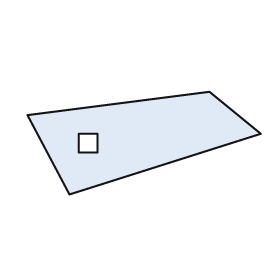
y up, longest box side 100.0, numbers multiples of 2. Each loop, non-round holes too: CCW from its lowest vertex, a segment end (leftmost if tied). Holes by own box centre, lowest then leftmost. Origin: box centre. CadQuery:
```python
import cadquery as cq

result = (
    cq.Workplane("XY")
    .moveTo(-32.0, -22.0)
    .lineTo(50.0, 4.0)
    .lineTo(28.0, 22.0)
    .lineTo(-50.0, 12.0)
    .close()
    .moveTo(-28.0, -4.0)
    .lineTo(-20.0, -4.0)
    .lineTo(-20.0, 4.0)
    .lineTo(-28.0, 4.0)
    .close()
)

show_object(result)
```